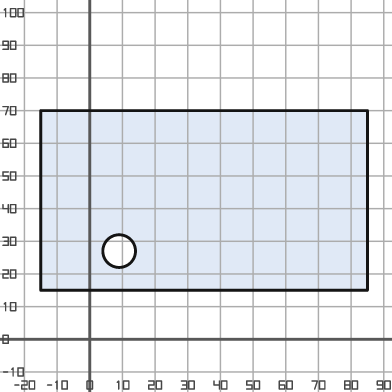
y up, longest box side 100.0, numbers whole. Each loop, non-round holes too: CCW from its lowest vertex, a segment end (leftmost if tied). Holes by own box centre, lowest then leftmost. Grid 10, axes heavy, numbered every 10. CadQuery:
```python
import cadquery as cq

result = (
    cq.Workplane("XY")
    .moveTo(-15.0, 15.0)
    .lineTo(85.0, 15.0)
    .lineTo(85.0, 70.0)
    .lineTo(-15.0, 70.0)
    .close()
    .moveTo(9.0, 27.0)
    .circle(5.0)
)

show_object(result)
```